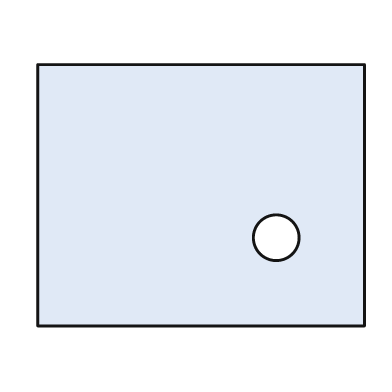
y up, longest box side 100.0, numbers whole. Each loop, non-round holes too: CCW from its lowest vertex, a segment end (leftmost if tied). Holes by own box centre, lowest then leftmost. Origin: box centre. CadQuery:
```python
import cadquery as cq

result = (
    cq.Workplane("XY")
    .moveTo(-50.0, -40.0)
    .lineTo(50.0, -40.0)
    .lineTo(50.0, 40.0)
    .lineTo(-50.0, 40.0)
    .close()
    .moveTo(23.0, -13.0)
    .circle(7.0)
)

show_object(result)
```